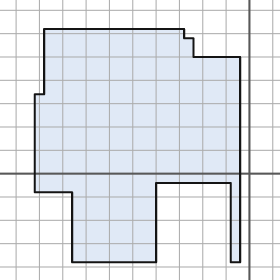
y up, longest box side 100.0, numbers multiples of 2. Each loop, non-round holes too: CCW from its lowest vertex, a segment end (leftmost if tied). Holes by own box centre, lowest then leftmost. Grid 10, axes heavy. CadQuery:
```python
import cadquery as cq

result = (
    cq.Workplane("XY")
    .moveTo(-76.0, -38.0)
    .lineTo(-40.0, -38.0)
    .lineTo(-40.0, -4.0)
    .lineTo(-8.0, -4.0)
    .lineTo(-8.0, -38.0)
    .lineTo(-4.0, -38.0)
    .lineTo(-4.0, 50.0)
    .lineTo(-24.0, 50.0)
    .lineTo(-24.0, 58.0)
    .lineTo(-28.0, 58.0)
    .lineTo(-28.0, 62.0)
    .lineTo(-88.0, 62.0)
    .lineTo(-88.0, 34.0)
    .lineTo(-92.0, 34.0)
    .lineTo(-92.0, -8.0)
    .lineTo(-76.0, -8.0)
    .close()
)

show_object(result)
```